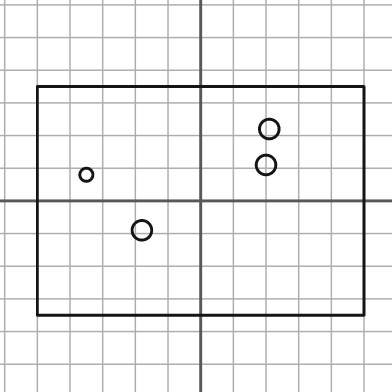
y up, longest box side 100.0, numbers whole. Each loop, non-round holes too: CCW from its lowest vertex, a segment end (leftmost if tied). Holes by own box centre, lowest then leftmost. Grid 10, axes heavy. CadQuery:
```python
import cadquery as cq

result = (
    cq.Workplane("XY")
    .moveTo(-50.0, -35.0)
    .lineTo(50.0, -35.0)
    .lineTo(50.0, 35.0)
    .lineTo(-50.0, 35.0)
    .close()
    .moveTo(-18.0, -9.0)
    .circle(3.0)
    .moveTo(-35.0, 8.0)
    .circle(2.0)
    .moveTo(20.0, 11.0)
    .circle(3.0)
    .moveTo(21.0, 22.0)
    .circle(3.0)
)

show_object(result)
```